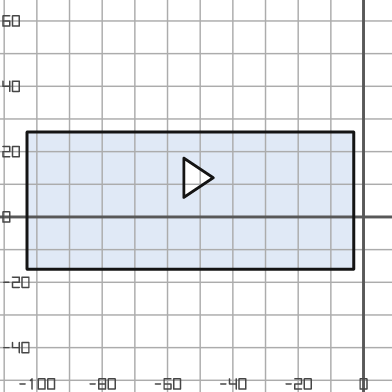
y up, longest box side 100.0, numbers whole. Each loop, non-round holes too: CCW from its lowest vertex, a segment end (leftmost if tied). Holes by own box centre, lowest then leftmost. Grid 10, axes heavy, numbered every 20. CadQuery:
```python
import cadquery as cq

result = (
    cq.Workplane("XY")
    .moveTo(-103.0, -16.0)
    .lineTo(-3.0, -16.0)
    .lineTo(-3.0, 26.0)
    .lineTo(-103.0, 26.0)
    .close()
    .moveTo(-55.0, 6.0)
    .lineTo(-46.0, 12.0)
    .lineTo(-55.0, 18.0)
    .close()
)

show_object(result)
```